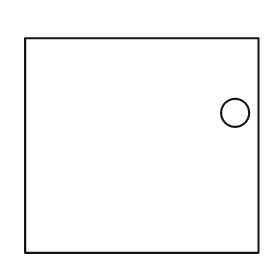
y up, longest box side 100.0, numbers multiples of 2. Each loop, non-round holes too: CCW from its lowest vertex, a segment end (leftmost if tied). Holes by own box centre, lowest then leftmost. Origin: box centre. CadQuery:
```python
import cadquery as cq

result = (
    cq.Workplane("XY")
    .moveTo(-50.0, -46.0)
    .lineTo(50.0, -46.0)
    .lineTo(50.0, 46.0)
    .lineTo(-50.0, 46.0)
    .close()
    .moveTo(40.0, 14.0)
    .circle(6.0)
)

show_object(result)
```